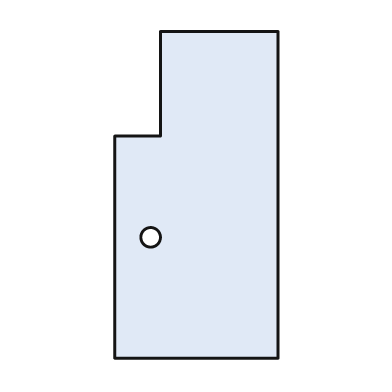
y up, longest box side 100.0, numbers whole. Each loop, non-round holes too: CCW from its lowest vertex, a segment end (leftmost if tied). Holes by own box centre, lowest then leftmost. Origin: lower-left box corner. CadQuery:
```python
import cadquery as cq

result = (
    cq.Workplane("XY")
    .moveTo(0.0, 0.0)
    .lineTo(50.0, 0.0)
    .lineTo(50.0, 100.0)
    .lineTo(14.0, 100.0)
    .lineTo(14.0, 68.0)
    .lineTo(0.0, 68.0)
    .close()
    .moveTo(11.0, 37.0)
    .circle(3.0)
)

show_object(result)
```